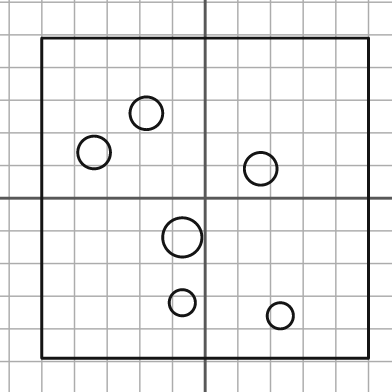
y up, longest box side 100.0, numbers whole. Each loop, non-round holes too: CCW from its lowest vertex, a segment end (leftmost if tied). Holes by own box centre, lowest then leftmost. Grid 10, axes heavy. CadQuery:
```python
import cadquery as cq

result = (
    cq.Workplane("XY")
    .moveTo(-50.0, -49.0)
    .lineTo(50.0, -49.0)
    .lineTo(50.0, 49.0)
    .lineTo(-50.0, 49.0)
    .close()
    .moveTo(23.0, -36.0)
    .circle(4.0)
    .moveTo(-7.0, -32.0)
    .circle(4.0)
    .moveTo(-7.0, -12.0)
    .circle(6.0)
    .moveTo(17.0, 9.0)
    .circle(5.0)
    .moveTo(-34.0, 14.0)
    .circle(5.0)
    .moveTo(-18.0, 26.0)
    .circle(5.0)
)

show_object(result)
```